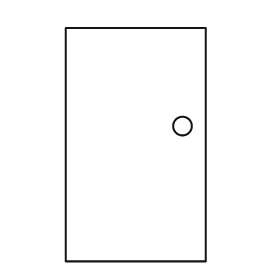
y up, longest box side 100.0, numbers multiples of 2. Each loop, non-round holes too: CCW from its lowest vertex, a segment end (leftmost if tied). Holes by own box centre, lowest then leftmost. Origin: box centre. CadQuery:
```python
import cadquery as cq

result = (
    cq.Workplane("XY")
    .moveTo(-30.0, -50.0)
    .lineTo(30.0, -50.0)
    .lineTo(30.0, 50.0)
    .lineTo(-30.0, 50.0)
    .close()
    .moveTo(20.0, 8.0)
    .circle(4.0)
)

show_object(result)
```